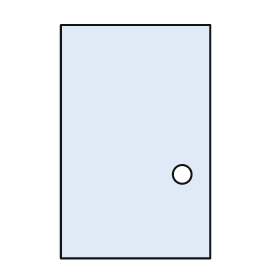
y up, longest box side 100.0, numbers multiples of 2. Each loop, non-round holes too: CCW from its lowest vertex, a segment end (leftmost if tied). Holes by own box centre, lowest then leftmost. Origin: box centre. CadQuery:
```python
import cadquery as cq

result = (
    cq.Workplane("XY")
    .moveTo(-32.0, -50.0)
    .lineTo(32.0, -50.0)
    .lineTo(32.0, 50.0)
    .lineTo(-32.0, 50.0)
    .close()
    .moveTo(20.0, -14.0)
    .circle(4.0)
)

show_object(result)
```